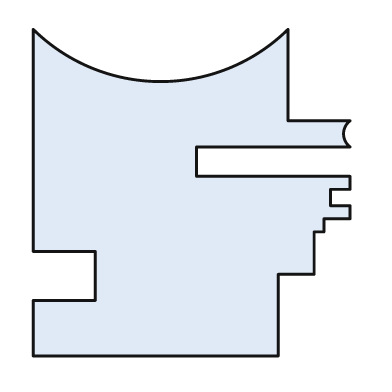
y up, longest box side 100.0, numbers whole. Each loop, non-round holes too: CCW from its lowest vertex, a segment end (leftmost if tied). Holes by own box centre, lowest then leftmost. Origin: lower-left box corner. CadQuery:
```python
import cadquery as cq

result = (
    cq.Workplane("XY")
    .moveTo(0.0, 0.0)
    .lineTo(75.0, 0.0)
    .lineTo(75.0, 25.0)
    .lineTo(86.0, 25.0)
    .lineTo(86.0, 38.0)
    .lineTo(89.0, 38.0)
    .lineTo(89.0, 42.0)
    .lineTo(97.0, 42.0)
    .lineTo(97.0, 46.0)
    .lineTo(91.0, 46.0)
    .lineTo(91.0, 51.0)
    .lineTo(97.0, 51.0)
    .lineTo(97.0, 55.0)
    .lineTo(50.0, 55.0)
    .lineTo(50.0, 64.0)
    .lineTo(97.0, 64.0)
    .threePointArc((95.0, 68.0), (97.0, 72.0))
    .lineTo(78.0, 72.0)
    .lineTo(78.0, 100.0)
    .threePointArc((39.0, 84.0), (0.0, 100.0))
    .lineTo(0.0, 32.0)
    .lineTo(19.0, 32.0)
    .lineTo(19.0, 17.0)
    .lineTo(0.0, 17.0)
    .close()
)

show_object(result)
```